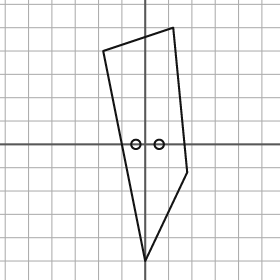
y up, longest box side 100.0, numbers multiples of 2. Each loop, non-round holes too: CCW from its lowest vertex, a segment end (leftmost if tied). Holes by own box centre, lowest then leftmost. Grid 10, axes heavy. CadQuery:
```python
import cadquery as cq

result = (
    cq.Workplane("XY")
    .moveTo(0.0, -50.0)
    .lineTo(18.0, -12.0)
    .lineTo(12.0, 50.0)
    .lineTo(-18.0, 40.0)
    .close()
    .moveTo(-4.0, 0.0)
    .circle(2.0)
    .moveTo(6.0, 0.0)
    .circle(2.0)
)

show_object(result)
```